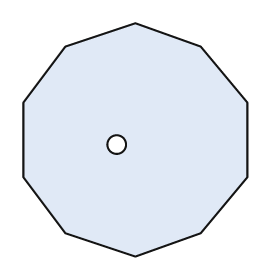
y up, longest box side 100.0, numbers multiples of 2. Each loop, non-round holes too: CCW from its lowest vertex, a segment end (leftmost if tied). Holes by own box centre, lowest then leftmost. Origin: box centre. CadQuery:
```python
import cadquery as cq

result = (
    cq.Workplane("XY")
    .moveTo(0.0, -50.0)
    .lineTo(28.0, -40.0)
    .lineTo(48.0, -16.0)
    .lineTo(48.0, 16.0)
    .lineTo(28.0, 40.0)
    .lineTo(0.0, 50.0)
    .lineTo(-30.0, 40.0)
    .lineTo(-48.0, 16.0)
    .lineTo(-48.0, -16.0)
    .lineTo(-30.0, -40.0)
    .close()
    .moveTo(-8.0, -2.0)
    .circle(4.0)
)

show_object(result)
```